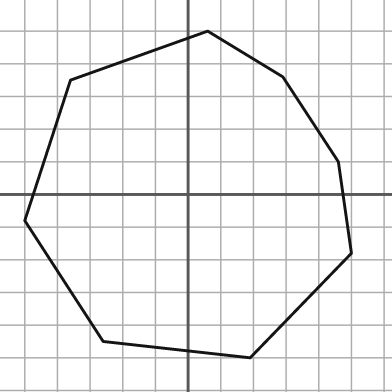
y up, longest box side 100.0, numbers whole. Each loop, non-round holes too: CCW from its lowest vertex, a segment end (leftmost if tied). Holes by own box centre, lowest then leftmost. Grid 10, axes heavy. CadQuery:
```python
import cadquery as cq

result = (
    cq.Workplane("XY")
    .moveTo(19.0, -50.0)
    .lineTo(50.0, -18.0)
    .lineTo(46.0, 10.0)
    .lineTo(29.0, 36.0)
    .lineTo(6.0, 50.0)
    .lineTo(-36.0, 35.0)
    .lineTo(-50.0, -8.0)
    .lineTo(-26.0, -45.0)
    .close()
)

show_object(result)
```